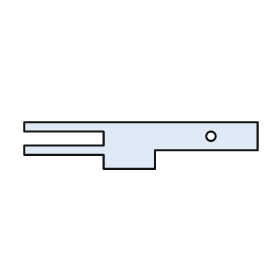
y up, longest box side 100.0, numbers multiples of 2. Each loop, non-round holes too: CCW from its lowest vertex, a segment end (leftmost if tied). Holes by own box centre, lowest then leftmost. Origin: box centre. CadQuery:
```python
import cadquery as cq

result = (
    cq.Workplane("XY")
    .moveTo(-16.0, -10.0)
    .lineTo(6.0, -10.0)
    .lineTo(6.0, -2.0)
    .lineTo(50.0, -2.0)
    .lineTo(50.0, 10.0)
    .lineTo(-50.0, 10.0)
    .lineTo(-50.0, 6.0)
    .lineTo(-16.0, 6.0)
    .lineTo(-16.0, 0.0)
    .lineTo(-50.0, 0.0)
    .lineTo(-50.0, -4.0)
    .lineTo(-16.0, -4.0)
    .close()
    .moveTo(30.0, 4.0)
    .circle(2.0)
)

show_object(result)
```